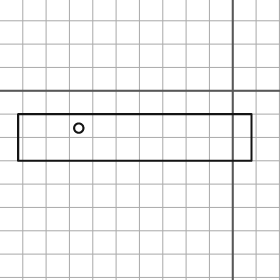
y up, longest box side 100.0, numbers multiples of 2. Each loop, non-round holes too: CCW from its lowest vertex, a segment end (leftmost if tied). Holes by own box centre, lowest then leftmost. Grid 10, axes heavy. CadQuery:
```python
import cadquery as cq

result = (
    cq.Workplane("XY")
    .moveTo(-92.0, -30.0)
    .lineTo(8.0, -30.0)
    .lineTo(8.0, -10.0)
    .lineTo(-92.0, -10.0)
    .close()
    .moveTo(-66.0, -16.0)
    .circle(2.0)
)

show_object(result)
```